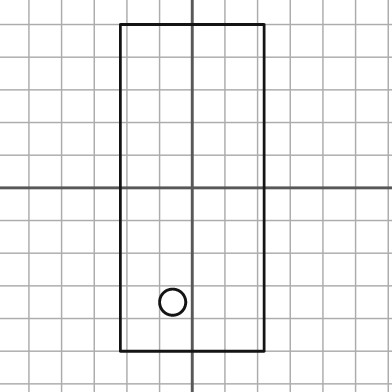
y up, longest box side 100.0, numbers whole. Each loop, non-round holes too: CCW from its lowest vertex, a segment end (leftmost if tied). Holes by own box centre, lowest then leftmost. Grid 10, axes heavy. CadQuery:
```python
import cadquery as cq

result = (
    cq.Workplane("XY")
    .moveTo(-22.0, -50.0)
    .lineTo(22.0, -50.0)
    .lineTo(22.0, 50.0)
    .lineTo(-22.0, 50.0)
    .close()
    .moveTo(-6.0, -35.0)
    .circle(4.0)
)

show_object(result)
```